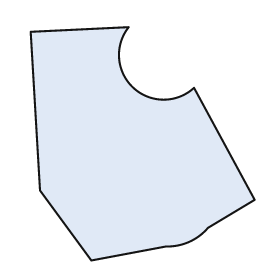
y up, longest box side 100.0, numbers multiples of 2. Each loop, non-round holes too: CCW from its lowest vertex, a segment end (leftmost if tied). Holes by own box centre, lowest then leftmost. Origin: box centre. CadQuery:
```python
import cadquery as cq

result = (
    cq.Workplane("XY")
    .moveTo(-22.0, -50.0)
    .lineTo(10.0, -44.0)
    .threePointArc((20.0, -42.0), (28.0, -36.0))
    .lineTo(48.0, -24.0)
    .lineTo(22.0, 24.0)
    .threePointArc((-4.0, 24.0), (-6.0, 50.0))
    .lineTo(-48.0, 48.0)
    .lineTo(-44.0, -20.0)
    .close()
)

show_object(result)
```